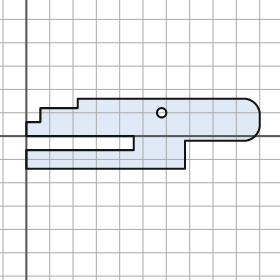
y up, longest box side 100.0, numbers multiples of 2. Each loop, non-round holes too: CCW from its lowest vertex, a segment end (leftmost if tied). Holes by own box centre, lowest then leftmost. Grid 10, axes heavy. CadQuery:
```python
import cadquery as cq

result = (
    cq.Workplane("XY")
    .moveTo(0.0, -14.0)
    .lineTo(68.0, -14.0)
    .lineTo(68.0, -2.0)
    .lineTo(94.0, -2.0)
    .threePointArc((98.0, 0.0), (100.0, 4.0))
    .lineTo(100.0, 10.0)
    .threePointArc((98.0, 14.0), (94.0, 16.0))
    .lineTo(22.0, 16.0)
    .lineTo(22.0, 12.0)
    .lineTo(6.0, 12.0)
    .lineTo(6.0, 6.0)
    .lineTo(0.0, 6.0)
    .lineTo(0.0, 0.0)
    .lineTo(46.0, 0.0)
    .lineTo(46.0, -6.0)
    .lineTo(0.0, -6.0)
    .close()
    .moveTo(58.0, 10.0)
    .circle(2.0)
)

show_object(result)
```